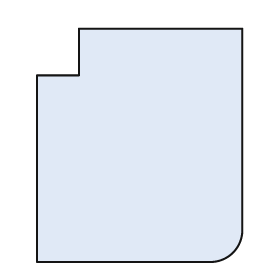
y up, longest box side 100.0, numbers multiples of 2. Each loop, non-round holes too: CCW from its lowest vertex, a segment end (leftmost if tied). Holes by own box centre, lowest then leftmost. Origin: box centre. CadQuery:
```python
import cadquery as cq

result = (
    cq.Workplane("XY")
    .moveTo(-44.0, -50.0)
    .lineTo(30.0, -50.0)
    .threePointArc((40.0, -46.0), (44.0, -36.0))
    .lineTo(44.0, 50.0)
    .lineTo(-26.0, 50.0)
    .lineTo(-26.0, 30.0)
    .lineTo(-44.0, 30.0)
    .close()
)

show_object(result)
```